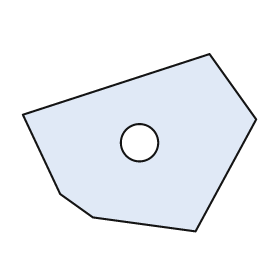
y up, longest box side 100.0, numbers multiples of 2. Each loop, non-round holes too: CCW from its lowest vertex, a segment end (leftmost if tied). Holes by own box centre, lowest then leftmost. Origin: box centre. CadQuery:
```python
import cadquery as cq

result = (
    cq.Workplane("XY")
    .moveTo(24.0, -38.0)
    .lineTo(50.0, 10.0)
    .lineTo(30.0, 38.0)
    .lineTo(-50.0, 12.0)
    .lineTo(-34.0, -22.0)
    .lineTo(-20.0, -32.0)
    .close()
    .moveTo(0.0, 0.0)
    .circle(8.0)
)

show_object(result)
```